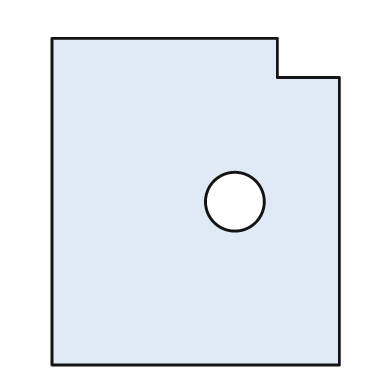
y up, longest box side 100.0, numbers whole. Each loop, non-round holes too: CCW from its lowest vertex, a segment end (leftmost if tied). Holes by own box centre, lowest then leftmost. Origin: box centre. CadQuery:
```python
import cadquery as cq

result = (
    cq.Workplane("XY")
    .moveTo(-44.0, -50.0)
    .lineTo(44.0, -50.0)
    .lineTo(44.0, 38.0)
    .lineTo(25.0, 38.0)
    .lineTo(25.0, 50.0)
    .lineTo(-44.0, 50.0)
    .close()
    .moveTo(12.0, 0.0)
    .circle(9.0)
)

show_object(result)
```